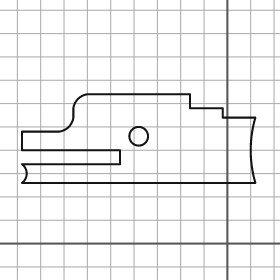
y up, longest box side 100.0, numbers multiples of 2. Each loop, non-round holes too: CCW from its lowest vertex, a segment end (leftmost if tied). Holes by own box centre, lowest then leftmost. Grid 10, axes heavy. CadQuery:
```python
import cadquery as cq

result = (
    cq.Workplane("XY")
    .moveTo(-88.0, 26.0)
    .lineTo(12.0, 26.0)
    .threePointArc((10.0, 40.0), (12.0, 54.0))
    .lineTo(-2.0, 54.0)
    .lineTo(-2.0, 58.0)
    .lineTo(-16.0, 58.0)
    .lineTo(-16.0, 64.0)
    .lineTo(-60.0, 64.0)
    .threePointArc((-64.0, 62.0), (-66.0, 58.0))
    .lineTo(-66.0, 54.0)
    .threePointArc((-68.0, 50.0), (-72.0, 48.0))
    .lineTo(-88.0, 48.0)
    .lineTo(-88.0, 40.0)
    .lineTo(-46.0, 40.0)
    .lineTo(-46.0, 34.0)
    .lineTo(-88.0, 34.0)
    .threePointArc((-86.0, 30.0), (-88.0, 26.0))
    .close()
    .moveTo(-38.0, 46.0)
    .circle(4.0)
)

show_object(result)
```